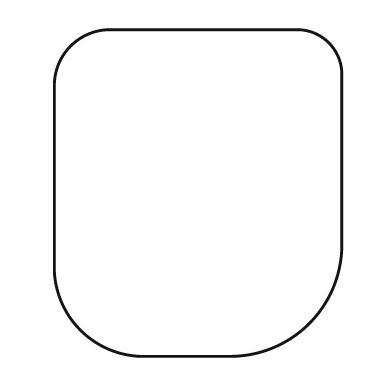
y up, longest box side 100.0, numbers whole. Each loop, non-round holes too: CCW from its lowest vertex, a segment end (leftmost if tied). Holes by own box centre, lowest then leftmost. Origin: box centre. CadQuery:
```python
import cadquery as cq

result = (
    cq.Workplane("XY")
    .moveTo(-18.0, -50.0)
    .lineTo(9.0, -50.0)
    .threePointArc((34.0, -40.0), (44.0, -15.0))
    .lineTo(44.0, 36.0)
    .threePointArc((40.0, 46.0), (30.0, 50.0))
    .lineTo(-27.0, 50.0)
    .threePointArc((-39.0, 45.0), (-44.0, 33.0))
    .lineTo(-44.0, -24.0)
    .threePointArc((-36.0, -42.0), (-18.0, -50.0))
    .close()
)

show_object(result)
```